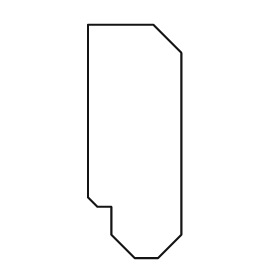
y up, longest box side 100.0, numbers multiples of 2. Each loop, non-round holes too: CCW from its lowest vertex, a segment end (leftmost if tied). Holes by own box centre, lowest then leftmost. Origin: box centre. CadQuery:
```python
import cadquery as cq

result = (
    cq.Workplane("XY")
    .moveTo(0.0, -50.0)
    .lineTo(10.0, -50.0)
    .lineTo(20.0, -40.0)
    .lineTo(20.0, 38.0)
    .lineTo(8.0, 50.0)
    .lineTo(-20.0, 50.0)
    .lineTo(-20.0, -24.0)
    .lineTo(-16.0, -28.0)
    .lineTo(-10.0, -28.0)
    .lineTo(-10.0, -40.0)
    .close()
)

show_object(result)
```